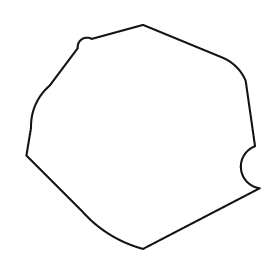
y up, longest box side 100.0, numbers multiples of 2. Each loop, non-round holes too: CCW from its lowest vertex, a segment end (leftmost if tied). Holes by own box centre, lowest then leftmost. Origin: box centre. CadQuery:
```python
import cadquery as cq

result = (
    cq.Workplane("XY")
    .moveTo(0.0, -48.0)
    .lineTo(50.0, -22.0)
    .threePointArc((42.0, -14.0), (48.0, -4.0))
    .lineTo(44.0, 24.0)
    .threePointArc((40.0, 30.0), (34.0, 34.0))
    .lineTo(0.0, 48.0)
    .lineTo(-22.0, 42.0)
    .threePointArc((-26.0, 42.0), (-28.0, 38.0))
    .lineTo(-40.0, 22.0)
    .threePointArc((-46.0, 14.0), (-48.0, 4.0))
    .lineTo(-50.0, -8.0)
    .lineTo(-26.0, -32.0)
    .threePointArc((-14.0, -42.0), (0.0, -48.0))
    .close()
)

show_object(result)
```